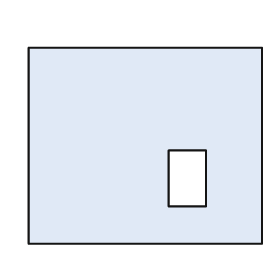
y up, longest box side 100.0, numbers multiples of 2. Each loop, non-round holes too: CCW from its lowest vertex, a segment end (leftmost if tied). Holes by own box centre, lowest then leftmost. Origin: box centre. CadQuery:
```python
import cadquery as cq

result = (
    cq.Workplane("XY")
    .moveTo(-50.0, -42.0)
    .lineTo(50.0, -42.0)
    .lineTo(50.0, 42.0)
    .lineTo(-50.0, 42.0)
    .close()
    .moveTo(10.0, -26.0)
    .lineTo(26.0, -26.0)
    .lineTo(26.0, -2.0)
    .lineTo(10.0, -2.0)
    .close()
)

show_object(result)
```